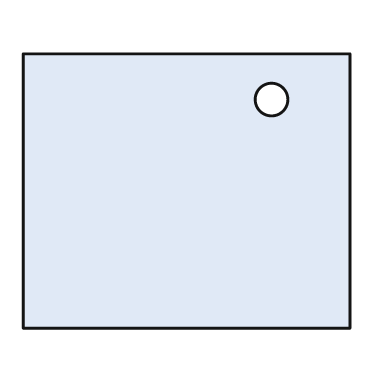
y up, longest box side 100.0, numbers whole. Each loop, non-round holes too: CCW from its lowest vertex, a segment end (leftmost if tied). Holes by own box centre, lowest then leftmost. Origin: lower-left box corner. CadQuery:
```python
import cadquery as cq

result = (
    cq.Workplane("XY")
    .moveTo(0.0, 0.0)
    .lineTo(100.0, 0.0)
    .lineTo(100.0, 84.0)
    .lineTo(0.0, 84.0)
    .close()
    .moveTo(76.0, 70.0)
    .circle(5.0)
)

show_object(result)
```